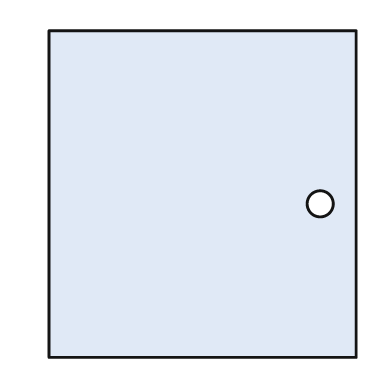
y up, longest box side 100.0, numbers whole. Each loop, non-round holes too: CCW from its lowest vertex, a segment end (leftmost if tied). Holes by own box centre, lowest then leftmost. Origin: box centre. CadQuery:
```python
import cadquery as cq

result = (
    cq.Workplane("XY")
    .moveTo(-47.0, -50.0)
    .lineTo(47.0, -50.0)
    .lineTo(47.0, 50.0)
    .lineTo(-47.0, 50.0)
    .close()
    .moveTo(36.0, -3.0)
    .circle(4.0)
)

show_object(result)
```